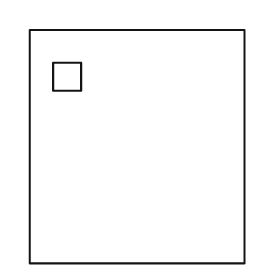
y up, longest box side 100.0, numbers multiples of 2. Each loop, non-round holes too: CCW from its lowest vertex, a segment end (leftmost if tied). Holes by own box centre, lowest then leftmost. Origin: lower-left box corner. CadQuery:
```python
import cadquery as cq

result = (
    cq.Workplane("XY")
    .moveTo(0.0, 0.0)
    .lineTo(92.0, 0.0)
    .lineTo(92.0, 100.0)
    .lineTo(0.0, 100.0)
    .close()
    .moveTo(10.0, 74.0)
    .lineTo(22.0, 74.0)
    .lineTo(22.0, 86.0)
    .lineTo(10.0, 86.0)
    .close()
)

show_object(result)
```